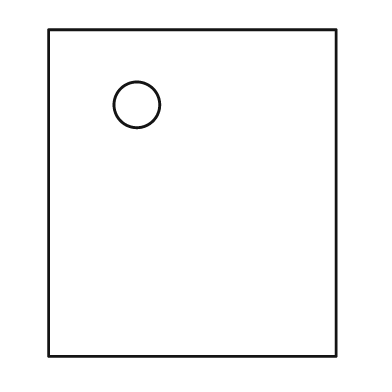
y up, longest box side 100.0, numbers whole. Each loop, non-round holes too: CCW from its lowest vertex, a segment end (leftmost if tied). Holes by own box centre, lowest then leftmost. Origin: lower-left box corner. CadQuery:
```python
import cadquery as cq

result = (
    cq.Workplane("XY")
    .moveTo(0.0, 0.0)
    .lineTo(88.0, 0.0)
    .lineTo(88.0, 100.0)
    .lineTo(0.0, 100.0)
    .close()
    .moveTo(27.0, 77.0)
    .circle(7.0)
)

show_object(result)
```